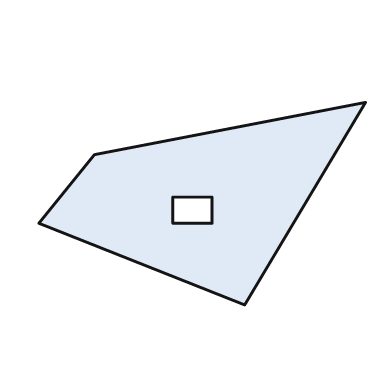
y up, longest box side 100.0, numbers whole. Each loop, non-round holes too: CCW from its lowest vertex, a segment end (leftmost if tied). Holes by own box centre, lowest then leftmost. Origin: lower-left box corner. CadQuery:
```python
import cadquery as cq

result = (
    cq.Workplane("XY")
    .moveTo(63.0, 0.0)
    .lineTo(100.0, 62.0)
    .lineTo(17.0, 46.0)
    .lineTo(0.0, 25.0)
    .close()
    .moveTo(41.0, 25.0)
    .lineTo(53.0, 25.0)
    .lineTo(53.0, 33.0)
    .lineTo(41.0, 33.0)
    .close()
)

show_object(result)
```